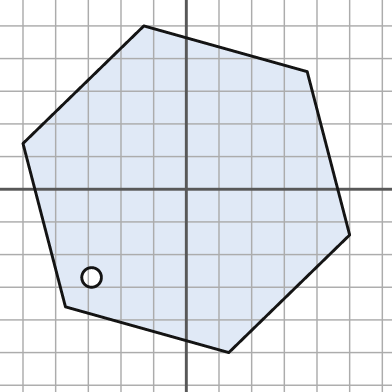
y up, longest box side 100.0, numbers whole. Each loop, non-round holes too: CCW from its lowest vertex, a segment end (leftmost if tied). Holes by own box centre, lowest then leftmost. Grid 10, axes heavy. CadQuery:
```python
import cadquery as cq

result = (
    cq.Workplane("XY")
    .moveTo(13.0, -50.0)
    .lineTo(50.0, -14.0)
    .lineTo(37.0, 36.0)
    .lineTo(-13.0, 50.0)
    .lineTo(-50.0, 14.0)
    .lineTo(-37.0, -36.0)
    .close()
    .moveTo(-29.0, -27.0)
    .circle(3.0)
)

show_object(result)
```